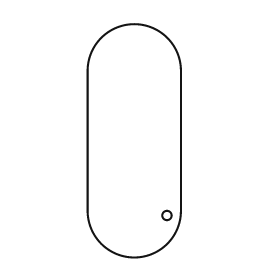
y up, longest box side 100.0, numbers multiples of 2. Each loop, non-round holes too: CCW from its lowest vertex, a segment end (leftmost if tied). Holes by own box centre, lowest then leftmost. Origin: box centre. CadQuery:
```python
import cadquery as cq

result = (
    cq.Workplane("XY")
    .moveTo(-20.0, -30.0)
    .threePointArc((0.0, -50.0), (20.0, -30.0))
    .lineTo(20.0, 30.0)
    .threePointArc((0.0, 50.0), (-20.0, 30.0))
    .close()
    .moveTo(14.0, -32.0)
    .circle(2.0)
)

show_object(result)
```